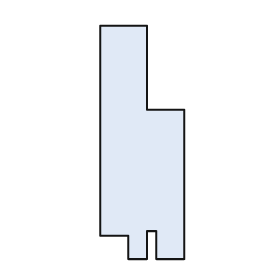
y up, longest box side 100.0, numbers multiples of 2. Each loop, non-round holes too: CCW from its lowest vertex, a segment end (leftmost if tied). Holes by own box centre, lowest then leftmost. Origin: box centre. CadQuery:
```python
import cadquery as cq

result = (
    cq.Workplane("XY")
    .moveTo(-6.0, -50.0)
    .lineTo(2.0, -50.0)
    .lineTo(2.0, -38.0)
    .lineTo(6.0, -38.0)
    .lineTo(6.0, -50.0)
    .lineTo(18.0, -50.0)
    .lineTo(18.0, 14.0)
    .lineTo(2.0, 14.0)
    .lineTo(2.0, 50.0)
    .lineTo(-18.0, 50.0)
    .lineTo(-18.0, -40.0)
    .lineTo(-6.0, -40.0)
    .close()
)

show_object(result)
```